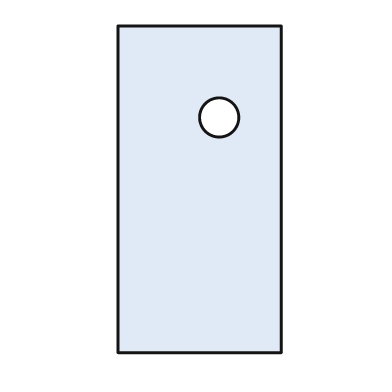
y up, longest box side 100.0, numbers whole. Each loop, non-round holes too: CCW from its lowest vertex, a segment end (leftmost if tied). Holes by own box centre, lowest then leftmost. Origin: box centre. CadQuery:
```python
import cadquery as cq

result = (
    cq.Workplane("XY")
    .moveTo(-25.0, -50.0)
    .lineTo(25.0, -50.0)
    .lineTo(25.0, 50.0)
    .lineTo(-25.0, 50.0)
    .close()
    .moveTo(6.0, 22.0)
    .circle(6.0)
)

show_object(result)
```